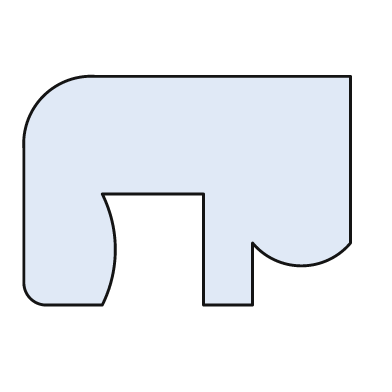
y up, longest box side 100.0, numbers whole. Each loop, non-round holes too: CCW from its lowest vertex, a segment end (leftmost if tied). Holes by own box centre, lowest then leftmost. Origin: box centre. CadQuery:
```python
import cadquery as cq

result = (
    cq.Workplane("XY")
    .moveTo(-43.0, -35.0)
    .lineTo(-26.0, -35.0)
    .threePointArc((-22.0, -18.0), (-26.0, -1.0))
    .lineTo(5.0, -1.0)
    .lineTo(5.0, -35.0)
    .lineTo(20.0, -35.0)
    .lineTo(20.0, -16.0)
    .threePointArc((35.0, -23.0), (50.0, -16.0))
    .lineTo(50.0, 35.0)
    .lineTo(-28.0, 35.0)
    .threePointArc((-44.0, 29.0), (-50.0, 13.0))
    .lineTo(-50.0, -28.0)
    .threePointArc((-48.0, -33.0), (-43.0, -35.0))
    .close()
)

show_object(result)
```